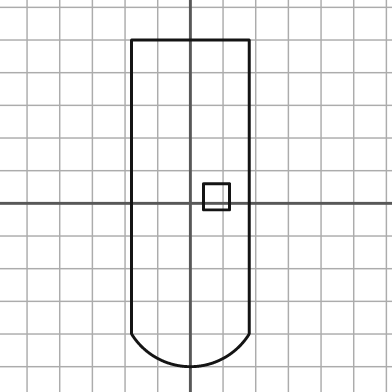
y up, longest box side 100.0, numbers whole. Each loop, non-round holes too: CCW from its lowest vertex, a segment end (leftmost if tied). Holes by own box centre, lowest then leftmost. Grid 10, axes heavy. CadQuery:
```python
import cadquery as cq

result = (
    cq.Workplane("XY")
    .moveTo(-18.0, -40.0)
    .threePointArc((0.0, -50.0), (18.0, -40.0))
    .lineTo(18.0, 50.0)
    .lineTo(-18.0, 50.0)
    .close()
    .moveTo(4.0, -2.0)
    .lineTo(12.0, -2.0)
    .lineTo(12.0, 6.0)
    .lineTo(4.0, 6.0)
    .close()
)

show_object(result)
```